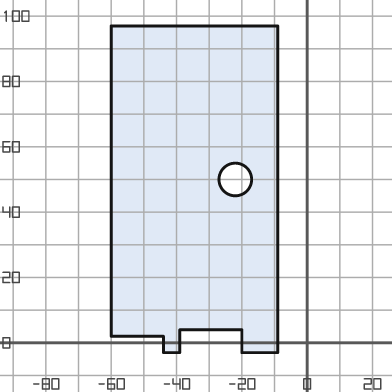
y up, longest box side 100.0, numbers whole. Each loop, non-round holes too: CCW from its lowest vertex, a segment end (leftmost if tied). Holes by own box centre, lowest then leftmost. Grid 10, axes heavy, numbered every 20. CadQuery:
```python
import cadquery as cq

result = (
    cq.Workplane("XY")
    .moveTo(-44.0, -3.0)
    .lineTo(-39.0, -3.0)
    .lineTo(-39.0, 4.0)
    .lineTo(-20.0, 4.0)
    .lineTo(-20.0, -3.0)
    .lineTo(-9.0, -3.0)
    .lineTo(-9.0, 97.0)
    .lineTo(-60.0, 97.0)
    .lineTo(-60.0, 2.0)
    .lineTo(-44.0, 2.0)
    .close()
    .moveTo(-22.0, 50.0)
    .circle(5.0)
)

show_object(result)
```